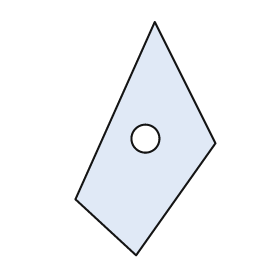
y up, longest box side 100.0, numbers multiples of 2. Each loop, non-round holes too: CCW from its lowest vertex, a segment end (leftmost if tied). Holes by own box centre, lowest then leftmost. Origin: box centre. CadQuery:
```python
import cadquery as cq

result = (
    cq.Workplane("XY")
    .moveTo(-4.0, -50.0)
    .lineTo(30.0, -2.0)
    .lineTo(4.0, 50.0)
    .lineTo(-30.0, -26.0)
    .close()
    .moveTo(0.0, 0.0)
    .circle(6.0)
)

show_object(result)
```